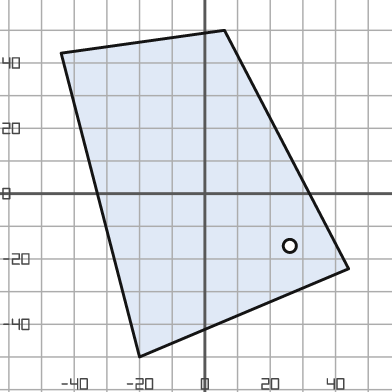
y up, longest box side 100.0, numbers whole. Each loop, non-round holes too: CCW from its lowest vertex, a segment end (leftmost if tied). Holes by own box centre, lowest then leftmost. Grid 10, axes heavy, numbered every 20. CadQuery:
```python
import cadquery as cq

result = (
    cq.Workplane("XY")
    .moveTo(-20.0, -50.0)
    .lineTo(44.0, -23.0)
    .lineTo(6.0, 50.0)
    .lineTo(-44.0, 43.0)
    .close()
    .moveTo(26.0, -16.0)
    .circle(2.0)
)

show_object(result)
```